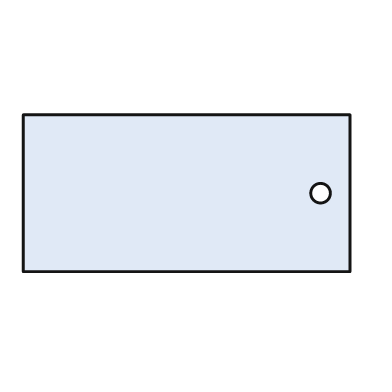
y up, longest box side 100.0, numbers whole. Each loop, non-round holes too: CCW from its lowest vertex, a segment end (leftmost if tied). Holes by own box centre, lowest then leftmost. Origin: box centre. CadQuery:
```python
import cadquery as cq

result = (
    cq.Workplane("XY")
    .moveTo(-50.0, -24.0)
    .lineTo(50.0, -24.0)
    .lineTo(50.0, 24.0)
    .lineTo(-50.0, 24.0)
    .close()
    .moveTo(41.0, 0.0)
    .circle(3.0)
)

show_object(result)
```